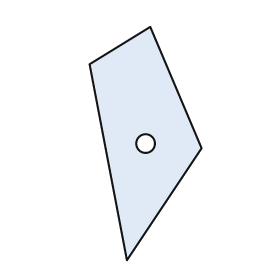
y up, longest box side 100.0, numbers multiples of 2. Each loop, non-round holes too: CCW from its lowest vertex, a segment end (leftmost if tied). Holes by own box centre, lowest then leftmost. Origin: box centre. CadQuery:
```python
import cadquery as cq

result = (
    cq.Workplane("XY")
    .moveTo(-8.0, -50.0)
    .lineTo(24.0, -2.0)
    .lineTo(2.0, 50.0)
    .lineTo(-24.0, 34.0)
    .close()
    .moveTo(0.0, 0.0)
    .circle(4.0)
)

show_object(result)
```